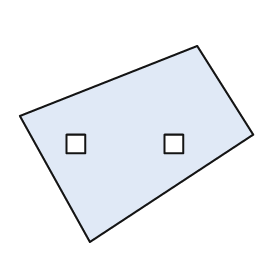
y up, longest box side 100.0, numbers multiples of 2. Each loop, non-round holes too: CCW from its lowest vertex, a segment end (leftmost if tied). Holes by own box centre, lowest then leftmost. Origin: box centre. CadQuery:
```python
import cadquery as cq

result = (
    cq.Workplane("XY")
    .moveTo(-20.0, -42.0)
    .lineTo(50.0, 4.0)
    .lineTo(26.0, 42.0)
    .lineTo(-50.0, 12.0)
    .close()
    .moveTo(-30.0, -4.0)
    .lineTo(-22.0, -4.0)
    .lineTo(-22.0, 4.0)
    .lineTo(-30.0, 4.0)
    .close()
    .moveTo(12.0, -4.0)
    .lineTo(20.0, -4.0)
    .lineTo(20.0, 4.0)
    .lineTo(12.0, 4.0)
    .close()
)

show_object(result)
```